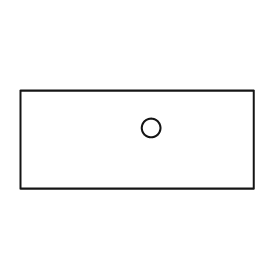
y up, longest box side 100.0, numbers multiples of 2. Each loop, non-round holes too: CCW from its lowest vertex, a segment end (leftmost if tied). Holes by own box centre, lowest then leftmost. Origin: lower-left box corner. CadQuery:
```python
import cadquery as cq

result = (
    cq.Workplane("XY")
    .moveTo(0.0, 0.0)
    .lineTo(100.0, 0.0)
    .lineTo(100.0, 42.0)
    .lineTo(0.0, 42.0)
    .close()
    .moveTo(56.0, 26.0)
    .circle(4.0)
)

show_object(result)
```